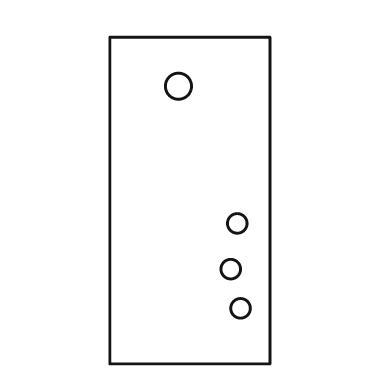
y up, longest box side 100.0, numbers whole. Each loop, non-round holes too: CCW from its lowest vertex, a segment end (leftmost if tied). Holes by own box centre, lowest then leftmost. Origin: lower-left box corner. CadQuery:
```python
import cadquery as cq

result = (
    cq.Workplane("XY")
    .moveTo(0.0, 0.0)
    .lineTo(49.0, 0.0)
    .lineTo(49.0, 100.0)
    .lineTo(0.0, 100.0)
    .close()
    .moveTo(40.0, 17.0)
    .circle(3.0)
    .moveTo(37.0, 29.0)
    .circle(3.0)
    .moveTo(39.0, 43.0)
    .circle(3.0)
    .moveTo(21.0, 85.0)
    .circle(4.0)
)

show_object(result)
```